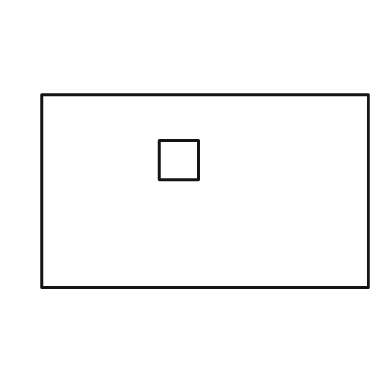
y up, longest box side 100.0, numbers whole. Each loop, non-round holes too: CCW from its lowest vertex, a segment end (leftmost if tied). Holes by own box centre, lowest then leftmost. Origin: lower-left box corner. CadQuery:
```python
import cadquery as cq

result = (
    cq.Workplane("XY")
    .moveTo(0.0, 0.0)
    .lineTo(100.0, 0.0)
    .lineTo(100.0, 59.0)
    .lineTo(0.0, 59.0)
    .close()
    .moveTo(36.0, 33.0)
    .lineTo(48.0, 33.0)
    .lineTo(48.0, 45.0)
    .lineTo(36.0, 45.0)
    .close()
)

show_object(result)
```